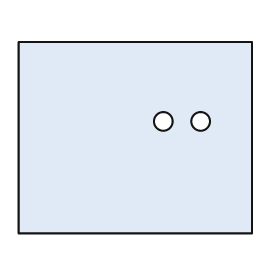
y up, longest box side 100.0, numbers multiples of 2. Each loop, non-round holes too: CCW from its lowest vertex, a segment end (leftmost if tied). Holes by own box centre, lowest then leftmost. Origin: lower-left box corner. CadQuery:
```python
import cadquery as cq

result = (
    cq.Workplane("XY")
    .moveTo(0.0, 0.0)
    .lineTo(100.0, 0.0)
    .lineTo(100.0, 82.0)
    .lineTo(0.0, 82.0)
    .close()
    .moveTo(62.0, 48.0)
    .circle(4.0)
    .moveTo(78.0, 48.0)
    .circle(4.0)
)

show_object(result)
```